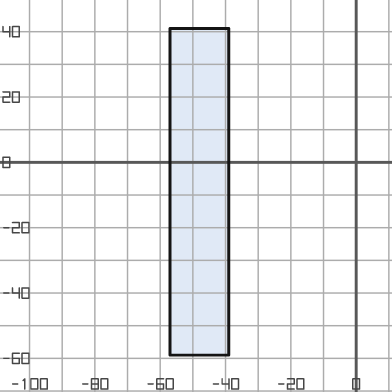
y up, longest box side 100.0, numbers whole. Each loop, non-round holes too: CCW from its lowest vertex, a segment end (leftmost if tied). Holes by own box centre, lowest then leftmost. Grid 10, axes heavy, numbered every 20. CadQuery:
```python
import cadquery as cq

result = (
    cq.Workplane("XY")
    .moveTo(-57.0, -59.0)
    .lineTo(-39.0, -59.0)
    .lineTo(-39.0, 41.0)
    .lineTo(-57.0, 41.0)
    .close()
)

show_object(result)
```